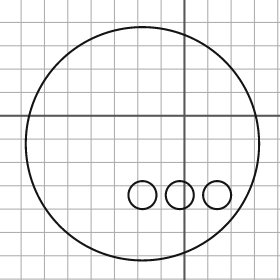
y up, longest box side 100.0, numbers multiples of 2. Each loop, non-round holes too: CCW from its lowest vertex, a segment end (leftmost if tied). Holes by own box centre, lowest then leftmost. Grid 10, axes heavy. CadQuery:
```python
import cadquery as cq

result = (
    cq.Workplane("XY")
    .moveTo(-18.0, -12.0)
    .circle(50.0)
    .moveTo(-18.0, -34.0)
    .circle(6.0)
    .moveTo(-2.0, -34.0)
    .circle(6.0)
    .moveTo(14.0, -34.0)
    .circle(6.0)
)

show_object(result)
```